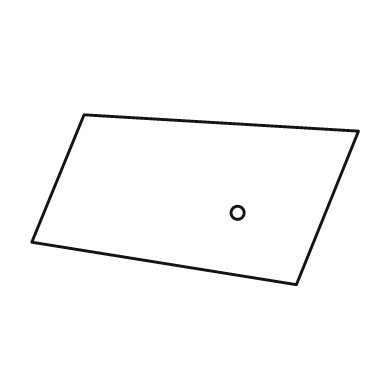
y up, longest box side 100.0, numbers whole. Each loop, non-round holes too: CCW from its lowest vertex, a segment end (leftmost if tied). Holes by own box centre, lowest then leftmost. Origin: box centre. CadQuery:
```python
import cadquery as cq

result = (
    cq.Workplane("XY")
    .moveTo(31.0, -26.0)
    .lineTo(50.0, 21.0)
    .lineTo(-34.0, 26.0)
    .lineTo(-50.0, -13.0)
    .close()
    .moveTo(13.0, -4.0)
    .circle(2.0)
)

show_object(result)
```